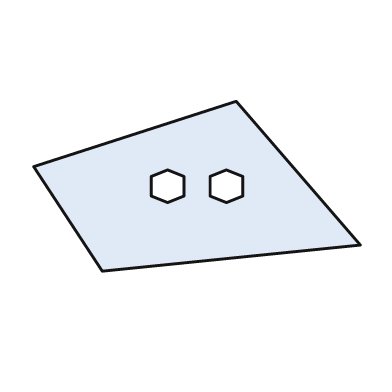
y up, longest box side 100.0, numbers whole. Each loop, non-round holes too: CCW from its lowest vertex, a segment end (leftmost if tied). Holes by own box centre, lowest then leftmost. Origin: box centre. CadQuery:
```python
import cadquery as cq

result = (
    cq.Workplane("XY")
    .moveTo(-29.0, -26.0)
    .lineTo(50.0, -18.0)
    .lineTo(12.0, 26.0)
    .lineTo(-50.0, 6.0)
    .close()
    .moveTo(-9.0, -5.0)
    .lineTo(-4.0, -3.0)
    .lineTo(-4.0, 3.0)
    .lineTo(-9.0, 5.0)
    .lineTo(-14.0, 3.0)
    .lineTo(-14.0, -3.0)
    .close()
    .moveTo(9.0, -5.0)
    .lineTo(14.0, -3.0)
    .lineTo(14.0, 3.0)
    .lineTo(9.0, 5.0)
    .lineTo(4.0, 3.0)
    .lineTo(4.0, -3.0)
    .close()
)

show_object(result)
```